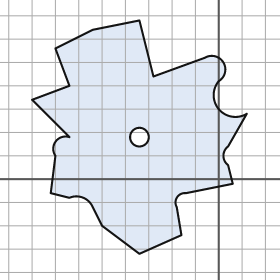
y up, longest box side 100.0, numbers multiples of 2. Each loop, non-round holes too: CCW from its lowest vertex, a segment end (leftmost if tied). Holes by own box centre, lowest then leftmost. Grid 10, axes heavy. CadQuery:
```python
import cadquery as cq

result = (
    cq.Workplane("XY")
    .moveTo(-34.0, -32.0)
    .lineTo(-16.0, -24.0)
    .lineTo(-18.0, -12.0)
    .threePointArc((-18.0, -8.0), (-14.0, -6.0))
    .lineTo(6.0, -2.0)
    .lineTo(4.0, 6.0)
    .threePointArc((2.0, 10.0), (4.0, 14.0))
    .lineTo(12.0, 28.0)
    .threePointArc((0.0, 30.0), (0.0, 42.0))
    .threePointArc((2.0, 50.0), (-6.0, 52.0))
    .lineTo(-28.0, 44.0)
    .lineTo(-34.0, 68.0)
    .lineTo(-54.0, 64.0)
    .lineTo(-70.0, 56.0)
    .lineTo(-64.0, 40.0)
    .lineTo(-80.0, 34.0)
    .lineTo(-64.0, 18.0)
    .threePointArc((-70.0, 16.0), (-70.0, 10.0))
    .lineTo(-72.0, -6.0)
    .lineTo(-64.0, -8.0)
    .threePointArc((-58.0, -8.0), (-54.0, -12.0))
    .lineTo(-50.0, -20.0)
    .close()
    .moveTo(-34.0, 18.0)
    .circle(4.0)
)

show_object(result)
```